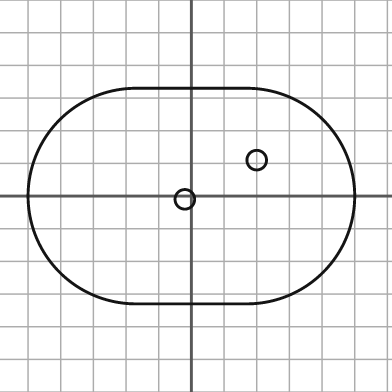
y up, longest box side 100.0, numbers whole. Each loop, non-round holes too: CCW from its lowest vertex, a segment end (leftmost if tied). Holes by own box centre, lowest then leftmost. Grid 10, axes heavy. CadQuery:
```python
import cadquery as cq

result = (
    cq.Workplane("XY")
    .moveTo(-17.0, -33.0)
    .lineTo(17.0, -33.0)
    .threePointArc((50.0, 0.0), (17.0, 33.0))
    .lineTo(-17.0, 33.0)
    .threePointArc((-50.0, 0.0), (-17.0, -33.0))
    .close()
    .moveTo(-2.0, -1.0)
    .circle(3.0)
    .moveTo(20.0, 11.0)
    .circle(3.0)
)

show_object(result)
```